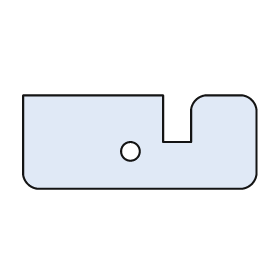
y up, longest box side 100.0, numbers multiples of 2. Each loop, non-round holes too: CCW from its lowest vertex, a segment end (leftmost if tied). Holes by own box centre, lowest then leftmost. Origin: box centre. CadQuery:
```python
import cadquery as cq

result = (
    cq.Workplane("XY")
    .moveTo(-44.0, -20.0)
    .lineTo(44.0, -20.0)
    .threePointArc((48.0, -18.0), (50.0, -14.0))
    .lineTo(50.0, 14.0)
    .threePointArc((48.0, 18.0), (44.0, 20.0))
    .lineTo(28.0, 20.0)
    .threePointArc((24.0, 18.0), (22.0, 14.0))
    .lineTo(22.0, 0.0)
    .lineTo(10.0, 0.0)
    .lineTo(10.0, 20.0)
    .lineTo(-50.0, 20.0)
    .lineTo(-50.0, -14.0)
    .threePointArc((-48.0, -18.0), (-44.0, -20.0))
    .close()
    .moveTo(-4.0, -4.0)
    .circle(4.0)
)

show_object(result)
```